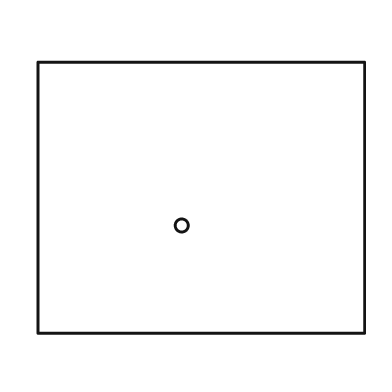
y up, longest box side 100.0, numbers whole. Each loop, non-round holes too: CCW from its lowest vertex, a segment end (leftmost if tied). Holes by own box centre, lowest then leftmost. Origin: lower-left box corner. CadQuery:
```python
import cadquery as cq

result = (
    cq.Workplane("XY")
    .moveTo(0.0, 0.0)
    .lineTo(100.0, 0.0)
    .lineTo(100.0, 83.0)
    .lineTo(0.0, 83.0)
    .close()
    .moveTo(44.0, 33.0)
    .circle(2.0)
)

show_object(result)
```